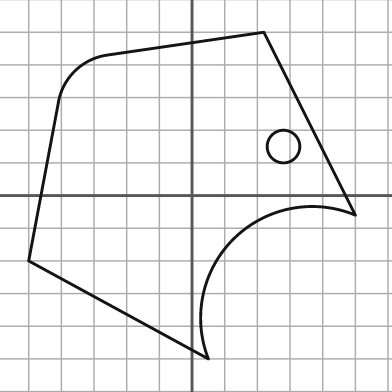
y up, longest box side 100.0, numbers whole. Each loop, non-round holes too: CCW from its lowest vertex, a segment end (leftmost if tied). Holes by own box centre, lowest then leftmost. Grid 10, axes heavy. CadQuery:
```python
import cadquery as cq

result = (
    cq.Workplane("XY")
    .moveTo(5.0, -50.0)
    .threePointArc((13.0, -13.0), (50.0, -6.0))
    .lineTo(22.0, 50.0)
    .lineTo(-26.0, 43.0)
    .threePointArc((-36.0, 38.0), (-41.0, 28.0))
    .lineTo(-50.0, -20.0)
    .close()
    .moveTo(28.0, 15.0)
    .circle(5.0)
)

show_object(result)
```